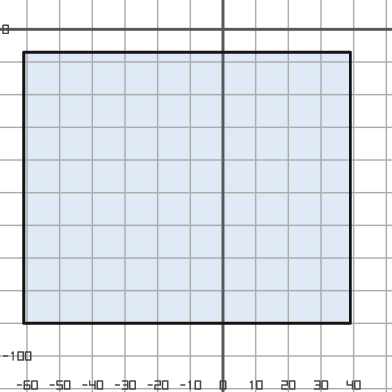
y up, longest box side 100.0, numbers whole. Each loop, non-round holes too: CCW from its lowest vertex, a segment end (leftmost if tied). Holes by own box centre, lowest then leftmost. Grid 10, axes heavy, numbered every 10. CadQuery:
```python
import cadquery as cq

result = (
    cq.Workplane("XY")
    .moveTo(-61.0, -90.0)
    .lineTo(39.0, -90.0)
    .lineTo(39.0, -7.0)
    .lineTo(-61.0, -7.0)
    .close()
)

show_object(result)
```